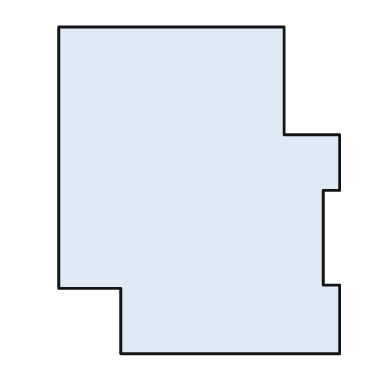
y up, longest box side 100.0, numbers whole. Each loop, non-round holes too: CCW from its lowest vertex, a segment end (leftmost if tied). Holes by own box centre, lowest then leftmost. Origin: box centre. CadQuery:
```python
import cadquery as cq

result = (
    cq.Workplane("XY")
    .moveTo(-24.0, -50.0)
    .lineTo(43.0, -50.0)
    .lineTo(43.0, -29.0)
    .lineTo(38.0, -29.0)
    .lineTo(38.0, 0.0)
    .lineTo(43.0, 0.0)
    .lineTo(43.0, 17.0)
    .lineTo(26.0, 17.0)
    .lineTo(26.0, 50.0)
    .lineTo(-43.0, 50.0)
    .lineTo(-43.0, -30.0)
    .lineTo(-24.0, -30.0)
    .close()
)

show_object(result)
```